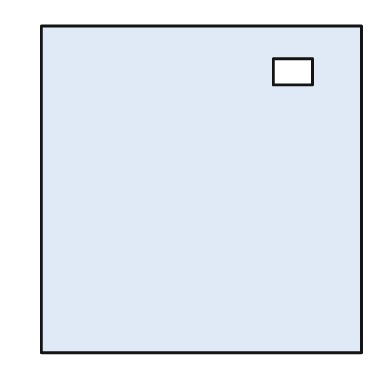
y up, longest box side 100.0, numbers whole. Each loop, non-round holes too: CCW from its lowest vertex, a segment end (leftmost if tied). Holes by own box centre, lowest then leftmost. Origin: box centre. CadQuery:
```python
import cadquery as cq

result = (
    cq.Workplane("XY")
    .moveTo(-49.0, -50.0)
    .lineTo(49.0, -50.0)
    .lineTo(49.0, 50.0)
    .lineTo(-49.0, 50.0)
    .close()
    .moveTo(22.0, 32.0)
    .lineTo(34.0, 32.0)
    .lineTo(34.0, 40.0)
    .lineTo(22.0, 40.0)
    .close()
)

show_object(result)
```